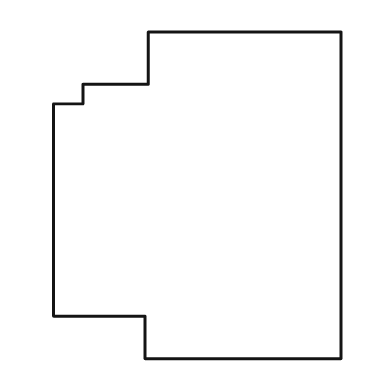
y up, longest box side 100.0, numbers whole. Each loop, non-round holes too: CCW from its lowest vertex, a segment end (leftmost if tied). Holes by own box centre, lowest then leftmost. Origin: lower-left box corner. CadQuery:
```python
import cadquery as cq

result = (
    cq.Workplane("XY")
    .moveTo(28.0, 0.0)
    .lineTo(88.0, 0.0)
    .lineTo(88.0, 100.0)
    .lineTo(29.0, 100.0)
    .lineTo(29.0, 84.0)
    .lineTo(9.0, 84.0)
    .lineTo(9.0, 78.0)
    .lineTo(0.0, 78.0)
    .lineTo(0.0, 13.0)
    .lineTo(28.0, 13.0)
    .close()
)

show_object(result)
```